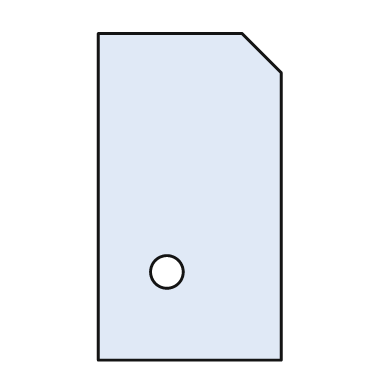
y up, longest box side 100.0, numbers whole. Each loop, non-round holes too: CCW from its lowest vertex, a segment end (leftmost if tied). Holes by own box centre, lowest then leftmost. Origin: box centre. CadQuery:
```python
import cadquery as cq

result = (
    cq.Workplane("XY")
    .moveTo(-28.0, -50.0)
    .lineTo(28.0, -50.0)
    .lineTo(28.0, 38.0)
    .lineTo(16.0, 50.0)
    .lineTo(-28.0, 50.0)
    .close()
    .moveTo(-7.0, -23.0)
    .circle(5.0)
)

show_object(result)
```